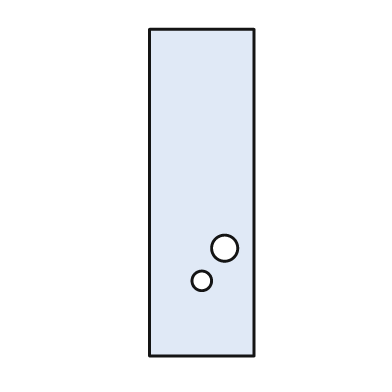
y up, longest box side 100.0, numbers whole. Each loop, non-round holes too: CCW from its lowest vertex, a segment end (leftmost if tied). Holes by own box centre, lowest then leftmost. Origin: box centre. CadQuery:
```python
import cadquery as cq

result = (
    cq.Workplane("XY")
    .moveTo(-16.0, -50.0)
    .lineTo(16.0, -50.0)
    .lineTo(16.0, 50.0)
    .lineTo(-16.0, 50.0)
    .close()
    .moveTo(0.0, -27.0)
    .circle(3.0)
    .moveTo(7.0, -17.0)
    .circle(4.0)
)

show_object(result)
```